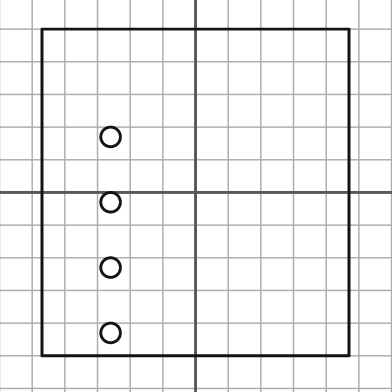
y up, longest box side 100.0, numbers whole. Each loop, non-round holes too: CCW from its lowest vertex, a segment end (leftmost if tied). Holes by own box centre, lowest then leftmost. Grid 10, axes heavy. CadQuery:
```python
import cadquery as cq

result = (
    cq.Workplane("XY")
    .moveTo(-47.0, -50.0)
    .lineTo(47.0, -50.0)
    .lineTo(47.0, 50.0)
    .lineTo(-47.0, 50.0)
    .close()
    .moveTo(-26.0, -43.0)
    .circle(3.0)
    .moveTo(-26.0, -23.0)
    .circle(3.0)
    .moveTo(-26.0, -3.0)
    .circle(3.0)
    .moveTo(-26.0, 17.0)
    .circle(3.0)
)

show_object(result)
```